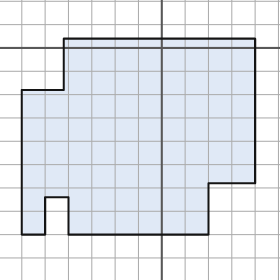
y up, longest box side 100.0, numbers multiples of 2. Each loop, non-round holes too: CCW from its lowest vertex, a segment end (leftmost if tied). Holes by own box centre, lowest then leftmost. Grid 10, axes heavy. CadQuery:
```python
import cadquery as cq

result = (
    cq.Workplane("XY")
    .moveTo(-60.0, -80.0)
    .lineTo(-50.0, -80.0)
    .lineTo(-50.0, -64.0)
    .lineTo(-40.0, -64.0)
    .lineTo(-40.0, -80.0)
    .lineTo(20.0, -80.0)
    .lineTo(20.0, -58.0)
    .lineTo(40.0, -58.0)
    .lineTo(40.0, 4.0)
    .lineTo(-42.0, 4.0)
    .lineTo(-42.0, -18.0)
    .lineTo(-60.0, -18.0)
    .close()
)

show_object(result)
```